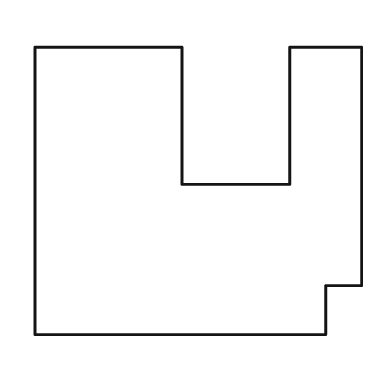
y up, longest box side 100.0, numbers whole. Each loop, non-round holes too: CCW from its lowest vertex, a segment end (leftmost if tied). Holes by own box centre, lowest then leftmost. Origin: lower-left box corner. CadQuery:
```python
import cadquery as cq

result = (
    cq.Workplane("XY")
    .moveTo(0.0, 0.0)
    .lineTo(89.0, 0.0)
    .lineTo(89.0, 15.0)
    .lineTo(100.0, 15.0)
    .lineTo(100.0, 88.0)
    .lineTo(78.0, 88.0)
    .lineTo(78.0, 46.0)
    .lineTo(45.0, 46.0)
    .lineTo(45.0, 88.0)
    .lineTo(0.0, 88.0)
    .close()
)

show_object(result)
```